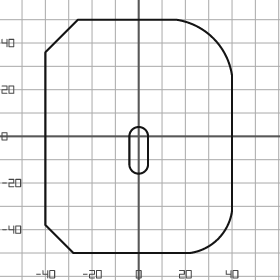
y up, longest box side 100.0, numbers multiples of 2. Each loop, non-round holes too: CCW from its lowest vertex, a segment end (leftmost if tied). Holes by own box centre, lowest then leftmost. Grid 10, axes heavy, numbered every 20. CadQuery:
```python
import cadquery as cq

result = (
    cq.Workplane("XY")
    .moveTo(-28.0, -50.0)
    .lineTo(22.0, -50.0)
    .threePointArc((34.0, -44.0), (40.0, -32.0))
    .lineTo(40.0, 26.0)
    .threePointArc((32.0, 42.0), (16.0, 50.0))
    .lineTo(-26.0, 50.0)
    .lineTo(-40.0, 36.0)
    .lineTo(-40.0, -38.0)
    .close()
    .moveTo(-4.0, -12.0)
    .threePointArc((0.0, -16.0), (4.0, -12.0))
    .lineTo(4.0, 0.0)
    .threePointArc((0.0, 4.0), (-4.0, 0.0))
    .close()
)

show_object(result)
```